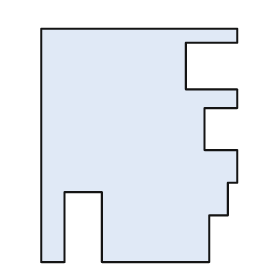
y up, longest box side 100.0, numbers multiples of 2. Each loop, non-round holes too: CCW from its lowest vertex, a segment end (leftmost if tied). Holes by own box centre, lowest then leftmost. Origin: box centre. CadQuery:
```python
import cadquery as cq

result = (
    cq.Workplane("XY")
    .moveTo(-42.0, -50.0)
    .lineTo(-32.0, -50.0)
    .lineTo(-32.0, -20.0)
    .lineTo(-16.0, -20.0)
    .lineTo(-16.0, -50.0)
    .lineTo(30.0, -50.0)
    .lineTo(30.0, -30.0)
    .lineTo(38.0, -30.0)
    .lineTo(38.0, -16.0)
    .lineTo(42.0, -16.0)
    .lineTo(42.0, -2.0)
    .lineTo(28.0, -2.0)
    .lineTo(28.0, 16.0)
    .lineTo(42.0, 16.0)
    .lineTo(42.0, 24.0)
    .lineTo(20.0, 24.0)
    .lineTo(20.0, 44.0)
    .lineTo(42.0, 44.0)
    .lineTo(42.0, 50.0)
    .lineTo(-42.0, 50.0)
    .close()
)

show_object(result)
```